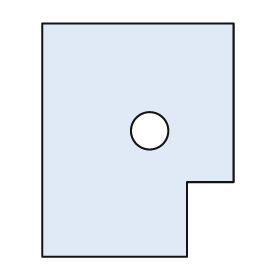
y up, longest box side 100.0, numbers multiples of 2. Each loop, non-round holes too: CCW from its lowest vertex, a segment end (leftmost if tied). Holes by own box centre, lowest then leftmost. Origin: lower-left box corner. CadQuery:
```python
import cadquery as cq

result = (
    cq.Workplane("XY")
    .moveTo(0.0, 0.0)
    .lineTo(62.0, 0.0)
    .lineTo(62.0, 32.0)
    .lineTo(82.0, 32.0)
    .lineTo(82.0, 100.0)
    .lineTo(0.0, 100.0)
    .close()
    .moveTo(46.0, 54.0)
    .circle(8.0)
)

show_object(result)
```